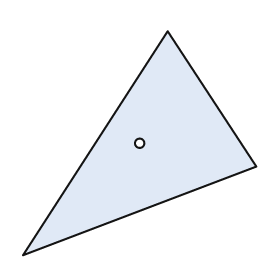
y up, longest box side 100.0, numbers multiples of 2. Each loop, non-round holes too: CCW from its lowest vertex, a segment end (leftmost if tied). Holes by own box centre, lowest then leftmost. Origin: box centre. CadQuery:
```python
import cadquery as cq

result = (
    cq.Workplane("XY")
    .moveTo(-50.0, -48.0)
    .lineTo(50.0, -10.0)
    .lineTo(12.0, 48.0)
    .close()
    .moveTo(0.0, 0.0)
    .circle(2.0)
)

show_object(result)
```